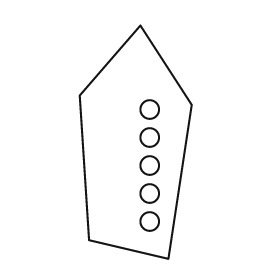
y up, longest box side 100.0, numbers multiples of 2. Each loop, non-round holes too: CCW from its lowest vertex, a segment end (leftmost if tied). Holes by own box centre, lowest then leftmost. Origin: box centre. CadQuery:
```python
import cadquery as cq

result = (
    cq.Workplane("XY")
    .moveTo(14.0, -50.0)
    .lineTo(24.0, 16.0)
    .lineTo(2.0, 50.0)
    .lineTo(-24.0, 20.0)
    .lineTo(-20.0, -42.0)
    .close()
    .moveTo(6.0, -34.0)
    .circle(4.0)
    .moveTo(6.0, -22.0)
    .circle(4.0)
    .moveTo(6.0, -10.0)
    .circle(4.0)
    .moveTo(6.0, 2.0)
    .circle(4.0)
    .moveTo(6.0, 14.0)
    .circle(4.0)
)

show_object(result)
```